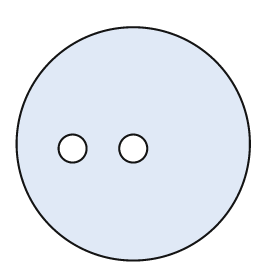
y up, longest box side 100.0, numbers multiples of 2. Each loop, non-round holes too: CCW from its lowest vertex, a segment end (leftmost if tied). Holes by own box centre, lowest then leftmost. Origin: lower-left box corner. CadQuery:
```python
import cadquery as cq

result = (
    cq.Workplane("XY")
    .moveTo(50.0, 50.0)
    .circle(50.0)
    .moveTo(24.0, 48.0)
    .circle(6.0)
    .moveTo(50.0, 48.0)
    .circle(6.0)
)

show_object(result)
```